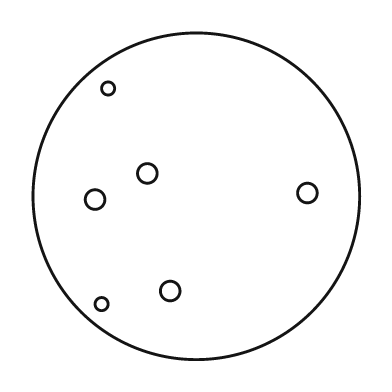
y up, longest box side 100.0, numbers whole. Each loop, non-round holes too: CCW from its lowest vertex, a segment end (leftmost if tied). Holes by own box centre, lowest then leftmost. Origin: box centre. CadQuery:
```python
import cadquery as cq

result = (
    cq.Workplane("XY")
    .moveTo(0.0, 0.0)
    .circle(50.0)
    .moveTo(-29.0, -33.0)
    .circle(2.0)
    .moveTo(-8.0, -29.0)
    .circle(3.0)
    .moveTo(-31.0, -1.0)
    .circle(3.0)
    .moveTo(34.0, 1.0)
    .circle(3.0)
    .moveTo(-15.0, 7.0)
    .circle(3.0)
    .moveTo(-27.0, 33.0)
    .circle(2.0)
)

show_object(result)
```